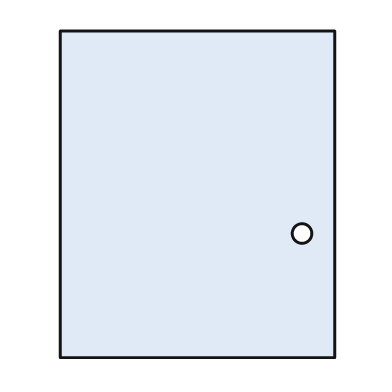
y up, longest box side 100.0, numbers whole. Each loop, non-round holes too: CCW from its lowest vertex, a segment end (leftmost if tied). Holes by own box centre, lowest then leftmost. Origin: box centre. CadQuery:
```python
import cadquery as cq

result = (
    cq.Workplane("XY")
    .moveTo(-42.0, -50.0)
    .lineTo(42.0, -50.0)
    .lineTo(42.0, 50.0)
    .lineTo(-42.0, 50.0)
    .close()
    .moveTo(32.0, -12.0)
    .circle(3.0)
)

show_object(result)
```